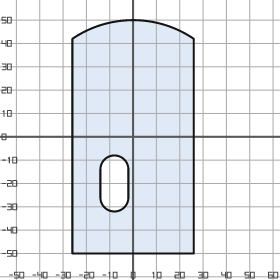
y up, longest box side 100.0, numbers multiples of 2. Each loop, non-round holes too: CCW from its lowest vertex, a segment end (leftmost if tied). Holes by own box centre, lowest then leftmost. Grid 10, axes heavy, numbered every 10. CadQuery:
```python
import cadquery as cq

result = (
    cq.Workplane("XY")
    .moveTo(-26.0, -50.0)
    .lineTo(26.0, -50.0)
    .lineTo(26.0, 42.0)
    .threePointArc((0.0, 50.0), (-26.0, 42.0))
    .close()
    .moveTo(-14.0, -26.0)
    .threePointArc((-8.0, -32.0), (-2.0, -26.0))
    .lineTo(-2.0, -14.0)
    .threePointArc((-8.0, -8.0), (-14.0, -14.0))
    .close()
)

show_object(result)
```